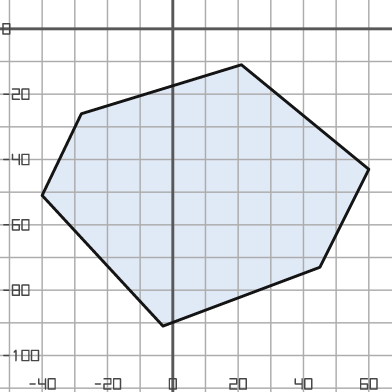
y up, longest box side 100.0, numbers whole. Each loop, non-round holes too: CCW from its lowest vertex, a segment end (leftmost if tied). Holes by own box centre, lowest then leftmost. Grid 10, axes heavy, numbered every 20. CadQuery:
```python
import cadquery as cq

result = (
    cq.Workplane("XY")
    .moveTo(-3.0, -91.0)
    .lineTo(45.0, -73.0)
    .lineTo(60.0, -43.0)
    .lineTo(21.0, -11.0)
    .lineTo(-28.0, -26.0)
    .lineTo(-40.0, -51.0)
    .close()
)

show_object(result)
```